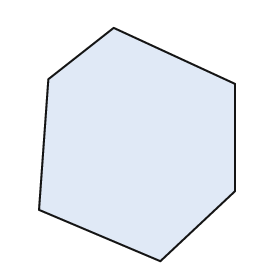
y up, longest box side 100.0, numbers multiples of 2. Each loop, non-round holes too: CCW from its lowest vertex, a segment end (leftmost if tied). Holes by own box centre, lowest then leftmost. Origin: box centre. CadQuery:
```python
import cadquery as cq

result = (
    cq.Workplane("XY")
    .moveTo(10.0, -50.0)
    .lineTo(42.0, -20.0)
    .lineTo(42.0, 26.0)
    .lineTo(-10.0, 50.0)
    .lineTo(-38.0, 28.0)
    .lineTo(-42.0, -28.0)
    .close()
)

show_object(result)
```